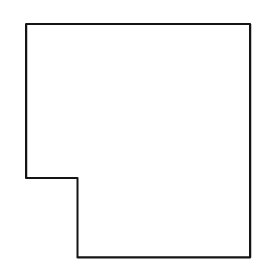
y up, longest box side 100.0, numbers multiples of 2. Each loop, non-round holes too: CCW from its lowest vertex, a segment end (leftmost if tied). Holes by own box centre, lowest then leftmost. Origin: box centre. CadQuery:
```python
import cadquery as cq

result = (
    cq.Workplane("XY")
    .moveTo(-26.0, -50.0)
    .lineTo(48.0, -50.0)
    .lineTo(48.0, 50.0)
    .lineTo(-48.0, 50.0)
    .lineTo(-48.0, -16.0)
    .lineTo(-26.0, -16.0)
    .close()
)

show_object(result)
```